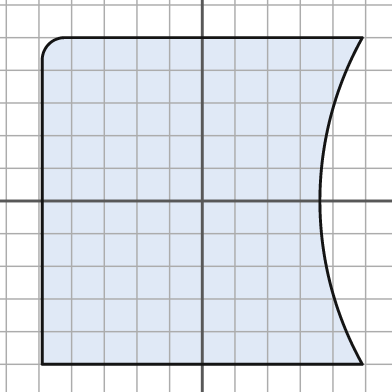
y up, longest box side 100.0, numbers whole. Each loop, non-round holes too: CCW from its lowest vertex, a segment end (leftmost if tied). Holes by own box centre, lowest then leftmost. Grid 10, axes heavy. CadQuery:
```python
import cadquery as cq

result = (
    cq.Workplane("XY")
    .moveTo(-49.0, -50.0)
    .lineTo(49.0, -50.0)
    .threePointArc((36.0, 0.0), (49.0, 50.0))
    .lineTo(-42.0, 50.0)
    .threePointArc((-47.0, 48.0), (-49.0, 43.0))
    .close()
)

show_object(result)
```